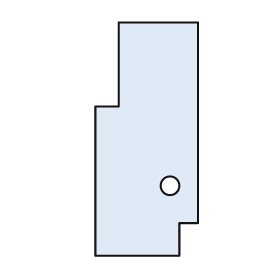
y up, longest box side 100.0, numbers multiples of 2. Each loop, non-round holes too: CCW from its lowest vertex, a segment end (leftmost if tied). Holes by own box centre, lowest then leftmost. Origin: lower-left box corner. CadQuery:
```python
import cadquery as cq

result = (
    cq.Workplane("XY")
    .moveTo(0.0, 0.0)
    .lineTo(36.0, 0.0)
    .lineTo(36.0, 14.0)
    .lineTo(44.0, 14.0)
    .lineTo(44.0, 100.0)
    .lineTo(10.0, 100.0)
    .lineTo(10.0, 64.0)
    .lineTo(0.0, 64.0)
    .close()
    .moveTo(32.0, 30.0)
    .circle(4.0)
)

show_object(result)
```